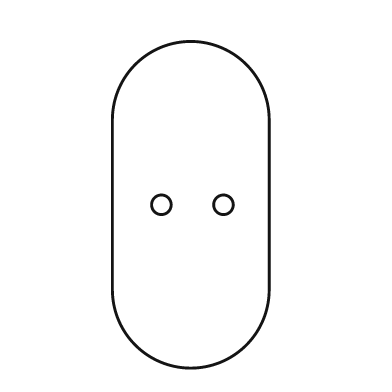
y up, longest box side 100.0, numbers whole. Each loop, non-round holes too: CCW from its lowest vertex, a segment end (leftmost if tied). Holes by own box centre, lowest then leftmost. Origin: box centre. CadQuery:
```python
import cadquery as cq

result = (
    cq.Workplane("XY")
    .moveTo(-24.0, -26.0)
    .threePointArc((0.0, -50.0), (24.0, -26.0))
    .lineTo(24.0, 26.0)
    .threePointArc((0.0, 50.0), (-24.0, 26.0))
    .close()
    .moveTo(-9.0, 0.0)
    .circle(3.0)
    .moveTo(10.0, 0.0)
    .circle(3.0)
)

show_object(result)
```